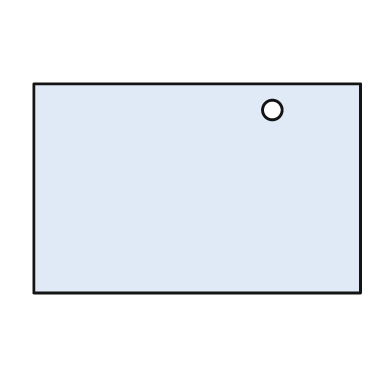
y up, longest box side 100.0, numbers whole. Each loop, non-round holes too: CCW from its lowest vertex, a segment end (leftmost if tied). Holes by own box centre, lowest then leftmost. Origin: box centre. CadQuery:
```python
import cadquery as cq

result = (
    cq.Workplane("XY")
    .moveTo(-50.0, -32.0)
    .lineTo(50.0, -32.0)
    .lineTo(50.0, 32.0)
    .lineTo(-50.0, 32.0)
    .close()
    .moveTo(23.0, 24.0)
    .circle(3.0)
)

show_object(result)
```